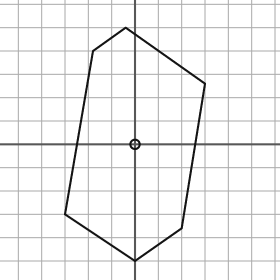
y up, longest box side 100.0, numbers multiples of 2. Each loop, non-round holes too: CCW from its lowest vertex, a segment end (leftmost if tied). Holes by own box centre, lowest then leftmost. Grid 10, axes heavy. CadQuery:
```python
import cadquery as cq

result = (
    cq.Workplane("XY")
    .moveTo(0.0, -50.0)
    .lineTo(20.0, -36.0)
    .lineTo(30.0, 26.0)
    .lineTo(-4.0, 50.0)
    .lineTo(-18.0, 40.0)
    .lineTo(-30.0, -30.0)
    .close()
    .moveTo(0.0, 0.0)
    .circle(2.0)
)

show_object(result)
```